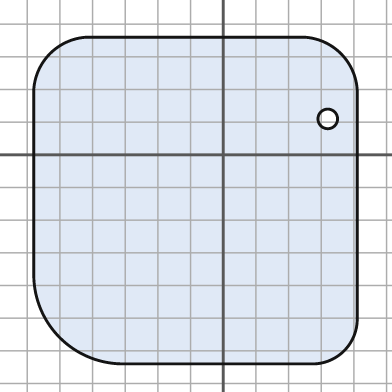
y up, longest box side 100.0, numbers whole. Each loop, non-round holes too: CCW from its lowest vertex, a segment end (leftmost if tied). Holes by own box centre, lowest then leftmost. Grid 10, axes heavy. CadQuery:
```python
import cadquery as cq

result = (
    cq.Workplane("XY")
    .moveTo(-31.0, -64.0)
    .lineTo(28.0, -64.0)
    .threePointArc((37.0, -60.0), (41.0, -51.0))
    .lineTo(41.0, 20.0)
    .threePointArc((36.0, 31.0), (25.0, 36.0))
    .lineTo(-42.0, 36.0)
    .threePointArc((-53.0, 31.0), (-58.0, 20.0))
    .lineTo(-58.0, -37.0)
    .threePointArc((-50.0, -56.0), (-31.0, -64.0))
    .close()
    .moveTo(32.0, 11.0)
    .circle(3.0)
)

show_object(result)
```